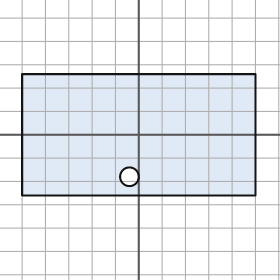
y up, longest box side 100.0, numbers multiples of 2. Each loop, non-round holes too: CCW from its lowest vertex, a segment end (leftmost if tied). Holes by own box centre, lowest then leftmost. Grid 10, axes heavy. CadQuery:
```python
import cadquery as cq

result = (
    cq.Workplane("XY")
    .moveTo(-50.0, -26.0)
    .lineTo(50.0, -26.0)
    .lineTo(50.0, 26.0)
    .lineTo(-50.0, 26.0)
    .close()
    .moveTo(-4.0, -18.0)
    .circle(4.0)
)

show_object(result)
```